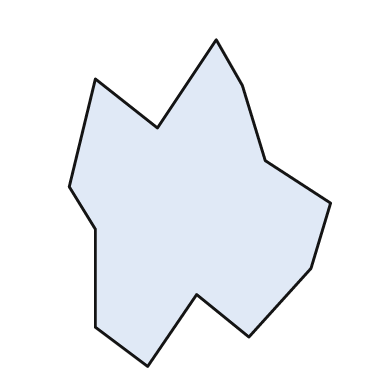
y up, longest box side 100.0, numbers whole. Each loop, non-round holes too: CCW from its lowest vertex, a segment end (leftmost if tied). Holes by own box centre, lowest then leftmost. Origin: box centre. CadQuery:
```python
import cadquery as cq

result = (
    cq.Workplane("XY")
    .moveTo(-16.0, -50.0)
    .lineTo(-1.0, -28.0)
    .lineTo(15.0, -41.0)
    .lineTo(34.0, -20.0)
    .lineTo(40.0, 0.0)
    .lineTo(20.0, 13.0)
    .lineTo(13.0, 36.0)
    .lineTo(5.0, 50.0)
    .lineTo(-13.0, 23.0)
    .lineTo(-32.0, 38.0)
    .lineTo(-40.0, 5.0)
    .lineTo(-32.0, -8.0)
    .lineTo(-32.0, -38.0)
    .close()
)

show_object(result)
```